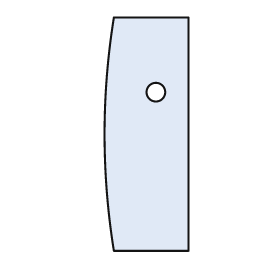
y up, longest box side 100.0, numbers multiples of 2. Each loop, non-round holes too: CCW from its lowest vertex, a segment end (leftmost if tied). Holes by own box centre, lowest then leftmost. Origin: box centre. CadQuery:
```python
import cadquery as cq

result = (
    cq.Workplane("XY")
    .moveTo(-14.0, -50.0)
    .lineTo(18.0, -50.0)
    .lineTo(18.0, 50.0)
    .lineTo(-14.0, 50.0)
    .threePointArc((-18.0, 0.0), (-14.0, -50.0))
    .close()
    .moveTo(4.0, 18.0)
    .circle(4.0)
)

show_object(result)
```